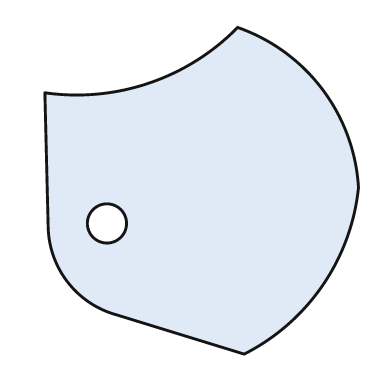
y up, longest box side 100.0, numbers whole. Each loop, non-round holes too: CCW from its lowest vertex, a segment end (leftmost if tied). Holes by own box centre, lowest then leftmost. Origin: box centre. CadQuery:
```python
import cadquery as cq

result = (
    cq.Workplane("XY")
    .moveTo(13.0, -50.0)
    .threePointArc((37.0, -29.0), (48.0, 1.0))
    .threePointArc((37.0, 31.0), (11.0, 50.0))
    .threePointArc((-16.0, 33.0), (-48.0, 30.0))
    .lineTo(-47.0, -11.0)
    .threePointArc((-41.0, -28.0), (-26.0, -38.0))
    .close()
    .moveTo(-29.0, -10.0)
    .circle(6.0)
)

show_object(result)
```